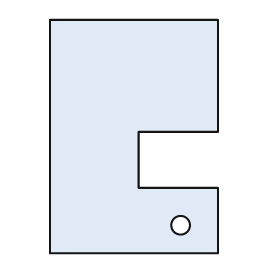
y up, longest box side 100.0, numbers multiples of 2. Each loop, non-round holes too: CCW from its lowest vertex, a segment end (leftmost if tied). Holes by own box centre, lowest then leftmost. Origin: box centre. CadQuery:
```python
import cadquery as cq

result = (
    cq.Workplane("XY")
    .moveTo(-36.0, -50.0)
    .lineTo(36.0, -50.0)
    .lineTo(36.0, -22.0)
    .lineTo(2.0, -22.0)
    .lineTo(2.0, 2.0)
    .lineTo(36.0, 2.0)
    .lineTo(36.0, 50.0)
    .lineTo(-36.0, 50.0)
    .close()
    .moveTo(20.0, -38.0)
    .circle(4.0)
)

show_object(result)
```